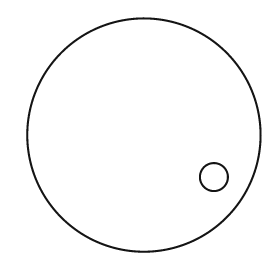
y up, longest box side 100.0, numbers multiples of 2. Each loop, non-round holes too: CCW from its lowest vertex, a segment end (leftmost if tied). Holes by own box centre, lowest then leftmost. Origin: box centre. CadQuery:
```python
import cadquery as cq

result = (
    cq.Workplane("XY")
    .moveTo(0.0, 0.0)
    .circle(50.0)
    .moveTo(30.0, -18.0)
    .circle(6.0)
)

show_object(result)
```